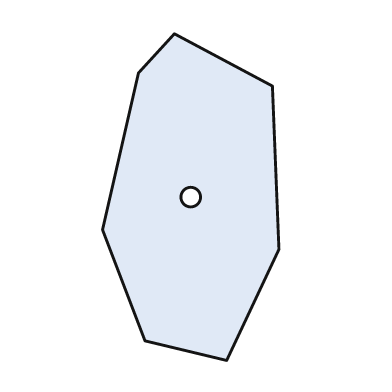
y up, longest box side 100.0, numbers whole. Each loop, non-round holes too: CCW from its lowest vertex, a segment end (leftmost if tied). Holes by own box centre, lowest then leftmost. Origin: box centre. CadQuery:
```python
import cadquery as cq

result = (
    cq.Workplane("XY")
    .moveTo(11.0, -50.0)
    .lineTo(27.0, -16.0)
    .lineTo(25.0, 34.0)
    .lineTo(-5.0, 50.0)
    .lineTo(-16.0, 38.0)
    .lineTo(-27.0, -10.0)
    .lineTo(-14.0, -44.0)
    .close()
    .moveTo(0.0, 0.0)
    .circle(3.0)
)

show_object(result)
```